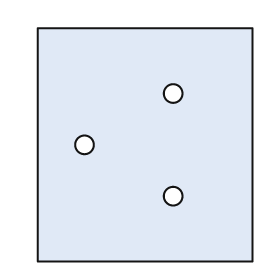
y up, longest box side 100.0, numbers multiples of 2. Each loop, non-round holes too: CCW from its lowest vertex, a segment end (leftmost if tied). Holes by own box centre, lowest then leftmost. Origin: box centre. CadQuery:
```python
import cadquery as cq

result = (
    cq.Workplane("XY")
    .moveTo(-46.0, -50.0)
    .lineTo(46.0, -50.0)
    .lineTo(46.0, 50.0)
    .lineTo(-46.0, 50.0)
    .close()
    .moveTo(12.0, -22.0)
    .circle(4.0)
    .moveTo(-26.0, 0.0)
    .circle(4.0)
    .moveTo(12.0, 22.0)
    .circle(4.0)
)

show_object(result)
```